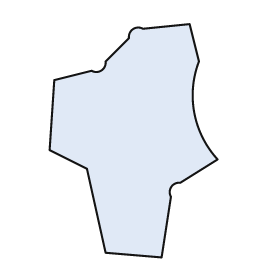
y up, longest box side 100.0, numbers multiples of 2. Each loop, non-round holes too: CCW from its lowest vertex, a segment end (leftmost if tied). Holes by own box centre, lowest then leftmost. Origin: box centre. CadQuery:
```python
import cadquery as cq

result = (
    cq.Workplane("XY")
    .moveTo(12.0, -50.0)
    .lineTo(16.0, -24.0)
    .threePointArc((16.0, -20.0), (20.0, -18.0))
    .lineTo(36.0, -8.0)
    .threePointArc((26.0, 12.0), (28.0, 34.0))
    .lineTo(24.0, 50.0)
    .lineTo(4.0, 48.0)
    .threePointArc((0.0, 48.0), (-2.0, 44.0))
    .lineTo(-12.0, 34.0)
    .threePointArc((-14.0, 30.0), (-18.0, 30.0))
    .lineTo(-34.0, 26.0)
    .lineTo(-36.0, -4.0)
    .lineTo(-20.0, -12.0)
    .lineTo(-12.0, -48.0)
    .close()
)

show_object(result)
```